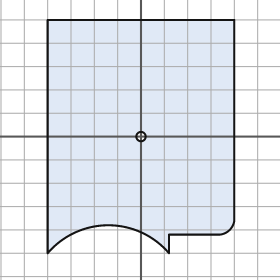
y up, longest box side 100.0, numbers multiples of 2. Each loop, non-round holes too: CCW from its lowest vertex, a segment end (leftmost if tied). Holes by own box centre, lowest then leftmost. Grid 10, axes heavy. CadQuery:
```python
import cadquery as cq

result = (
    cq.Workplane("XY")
    .moveTo(-40.0, -50.0)
    .threePointArc((-14.0, -38.0), (12.0, -50.0))
    .lineTo(12.0, -42.0)
    .lineTo(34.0, -42.0)
    .threePointArc((38.0, -40.0), (40.0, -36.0))
    .lineTo(40.0, 50.0)
    .lineTo(-40.0, 50.0)
    .close()
    .moveTo(0.0, 0.0)
    .circle(2.0)
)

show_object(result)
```